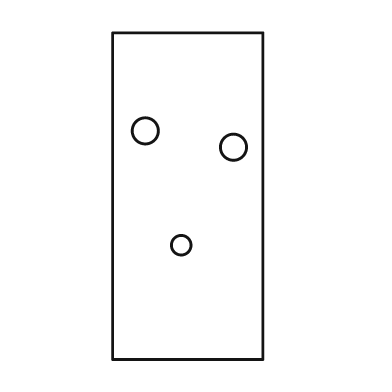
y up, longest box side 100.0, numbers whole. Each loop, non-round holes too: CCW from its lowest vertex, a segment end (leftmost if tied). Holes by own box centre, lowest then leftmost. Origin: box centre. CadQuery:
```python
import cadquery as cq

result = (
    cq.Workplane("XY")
    .moveTo(-23.0, -50.0)
    .lineTo(23.0, -50.0)
    .lineTo(23.0, 50.0)
    .lineTo(-23.0, 50.0)
    .close()
    .moveTo(-2.0, -15.0)
    .circle(3.0)
    .moveTo(14.0, 15.0)
    .circle(4.0)
    .moveTo(-13.0, 20.0)
    .circle(4.0)
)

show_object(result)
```